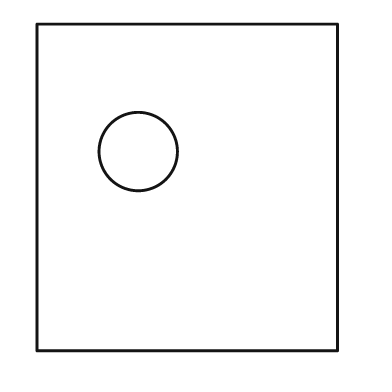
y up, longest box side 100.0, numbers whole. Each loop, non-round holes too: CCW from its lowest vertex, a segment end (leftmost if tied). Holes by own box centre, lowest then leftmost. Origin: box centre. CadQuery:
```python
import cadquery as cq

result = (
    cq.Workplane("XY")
    .moveTo(-46.0, -50.0)
    .lineTo(46.0, -50.0)
    .lineTo(46.0, 50.0)
    .lineTo(-46.0, 50.0)
    .close()
    .moveTo(-15.0, 11.0)
    .circle(12.0)
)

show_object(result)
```